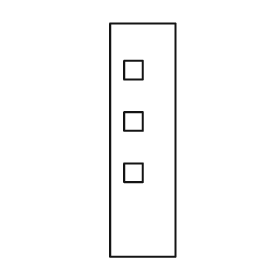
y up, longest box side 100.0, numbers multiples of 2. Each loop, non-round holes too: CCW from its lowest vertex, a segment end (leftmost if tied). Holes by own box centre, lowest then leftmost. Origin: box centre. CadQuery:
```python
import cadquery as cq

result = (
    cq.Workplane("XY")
    .moveTo(-14.0, -50.0)
    .lineTo(14.0, -50.0)
    .lineTo(14.0, 50.0)
    .lineTo(-14.0, 50.0)
    .close()
    .moveTo(-8.0, -18.0)
    .lineTo(0.0, -18.0)
    .lineTo(0.0, -10.0)
    .lineTo(-8.0, -10.0)
    .close()
    .moveTo(-8.0, 4.0)
    .lineTo(0.0, 4.0)
    .lineTo(0.0, 12.0)
    .lineTo(-8.0, 12.0)
    .close()
    .moveTo(-8.0, 26.0)
    .lineTo(0.0, 26.0)
    .lineTo(0.0, 34.0)
    .lineTo(-8.0, 34.0)
    .close()
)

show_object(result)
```